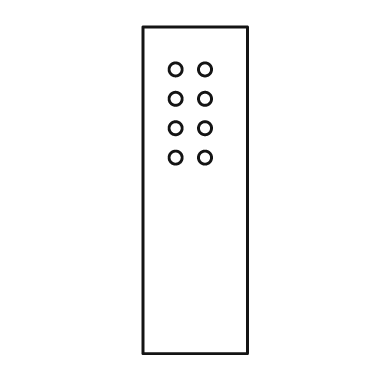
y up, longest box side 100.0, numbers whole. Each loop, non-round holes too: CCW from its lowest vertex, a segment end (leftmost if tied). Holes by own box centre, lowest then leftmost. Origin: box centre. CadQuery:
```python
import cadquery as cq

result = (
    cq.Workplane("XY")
    .moveTo(-16.0, -50.0)
    .lineTo(16.0, -50.0)
    .lineTo(16.0, 50.0)
    .lineTo(-16.0, 50.0)
    .close()
    .moveTo(-6.0, 10.0)
    .circle(2.0)
    .moveTo(3.0, 10.0)
    .circle(2.0)
    .moveTo(-6.0, 19.0)
    .circle(2.0)
    .moveTo(3.0, 19.0)
    .circle(2.0)
    .moveTo(-6.0, 28.0)
    .circle(2.0)
    .moveTo(3.0, 28.0)
    .circle(2.0)
    .moveTo(-6.0, 37.0)
    .circle(2.0)
    .moveTo(3.0, 37.0)
    .circle(2.0)
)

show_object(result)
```